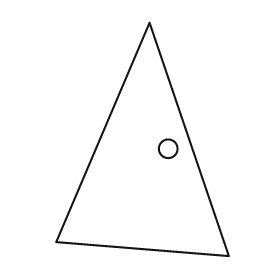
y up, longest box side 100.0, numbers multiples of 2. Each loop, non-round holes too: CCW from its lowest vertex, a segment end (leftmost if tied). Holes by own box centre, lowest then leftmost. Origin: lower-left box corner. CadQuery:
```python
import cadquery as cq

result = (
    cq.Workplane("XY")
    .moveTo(74.0, 0.0)
    .lineTo(40.0, 100.0)
    .lineTo(0.0, 6.0)
    .close()
    .moveTo(48.0, 46.0)
    .circle(4.0)
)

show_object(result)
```